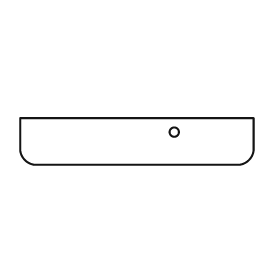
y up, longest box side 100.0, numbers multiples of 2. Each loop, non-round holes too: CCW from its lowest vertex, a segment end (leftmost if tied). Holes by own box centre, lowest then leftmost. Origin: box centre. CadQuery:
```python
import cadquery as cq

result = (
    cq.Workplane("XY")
    .moveTo(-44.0, -10.0)
    .lineTo(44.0, -10.0)
    .threePointArc((48.0, -8.0), (50.0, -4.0))
    .lineTo(50.0, 10.0)
    .lineTo(-50.0, 10.0)
    .lineTo(-50.0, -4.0)
    .threePointArc((-48.0, -8.0), (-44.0, -10.0))
    .close()
    .moveTo(16.0, 4.0)
    .circle(2.0)
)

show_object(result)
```